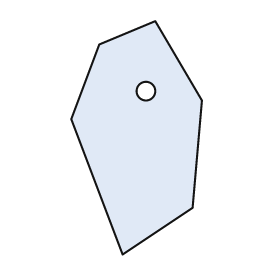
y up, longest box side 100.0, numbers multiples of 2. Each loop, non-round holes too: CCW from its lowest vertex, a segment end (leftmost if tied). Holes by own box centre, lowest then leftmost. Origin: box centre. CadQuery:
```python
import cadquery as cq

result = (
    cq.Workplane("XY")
    .moveTo(-6.0, -50.0)
    .lineTo(24.0, -30.0)
    .lineTo(28.0, 16.0)
    .lineTo(8.0, 50.0)
    .lineTo(-16.0, 40.0)
    .lineTo(-28.0, 8.0)
    .close()
    .moveTo(4.0, 20.0)
    .circle(4.0)
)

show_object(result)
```